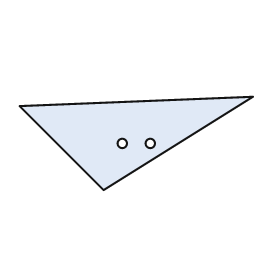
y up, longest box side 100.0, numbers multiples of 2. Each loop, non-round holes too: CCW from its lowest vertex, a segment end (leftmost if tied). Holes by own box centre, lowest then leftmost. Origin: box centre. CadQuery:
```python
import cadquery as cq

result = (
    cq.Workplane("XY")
    .moveTo(-14.0, -20.0)
    .lineTo(50.0, 20.0)
    .lineTo(-50.0, 16.0)
    .close()
    .moveTo(-6.0, 0.0)
    .circle(2.0)
    .moveTo(6.0, 0.0)
    .circle(2.0)
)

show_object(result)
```